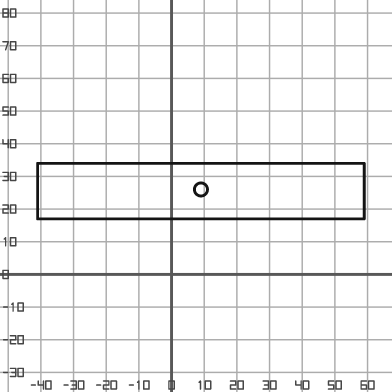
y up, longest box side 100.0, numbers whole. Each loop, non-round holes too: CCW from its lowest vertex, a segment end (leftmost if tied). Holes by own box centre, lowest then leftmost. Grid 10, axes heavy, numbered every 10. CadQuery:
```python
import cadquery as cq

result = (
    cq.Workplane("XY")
    .moveTo(-41.0, 17.0)
    .lineTo(59.0, 17.0)
    .lineTo(59.0, 34.0)
    .lineTo(-41.0, 34.0)
    .close()
    .moveTo(9.0, 26.0)
    .circle(2.0)
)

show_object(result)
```